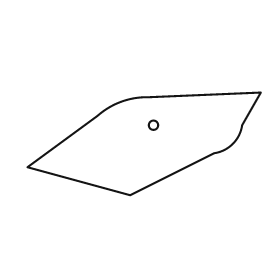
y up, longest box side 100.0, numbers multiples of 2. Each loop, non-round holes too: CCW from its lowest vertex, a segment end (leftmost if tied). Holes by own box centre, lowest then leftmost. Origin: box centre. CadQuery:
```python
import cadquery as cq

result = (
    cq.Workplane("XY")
    .moveTo(-6.0, -22.0)
    .lineTo(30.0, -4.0)
    .threePointArc((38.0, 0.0), (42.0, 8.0))
    .lineTo(50.0, 22.0)
    .lineTo(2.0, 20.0)
    .threePointArc((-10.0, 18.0), (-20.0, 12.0))
    .lineTo(-50.0, -10.0)
    .close()
    .moveTo(4.0, 8.0)
    .circle(2.0)
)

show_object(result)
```